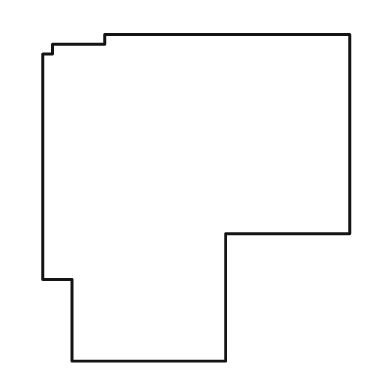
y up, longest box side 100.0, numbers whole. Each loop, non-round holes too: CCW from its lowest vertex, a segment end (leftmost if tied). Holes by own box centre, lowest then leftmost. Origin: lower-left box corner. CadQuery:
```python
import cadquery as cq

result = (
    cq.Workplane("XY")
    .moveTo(9.0, 0.0)
    .lineTo(56.0, 0.0)
    .lineTo(56.0, 39.0)
    .lineTo(94.0, 39.0)
    .lineTo(94.0, 100.0)
    .lineTo(19.0, 100.0)
    .lineTo(19.0, 97.0)
    .lineTo(3.0, 97.0)
    .lineTo(3.0, 94.0)
    .lineTo(0.0, 94.0)
    .lineTo(0.0, 25.0)
    .lineTo(9.0, 25.0)
    .close()
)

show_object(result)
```